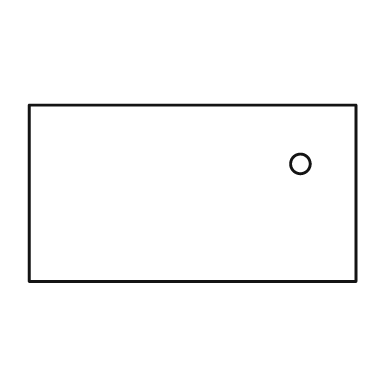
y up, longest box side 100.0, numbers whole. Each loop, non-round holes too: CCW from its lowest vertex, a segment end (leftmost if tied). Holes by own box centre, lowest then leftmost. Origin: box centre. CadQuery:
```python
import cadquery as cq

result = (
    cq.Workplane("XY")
    .moveTo(-50.0, -27.0)
    .lineTo(50.0, -27.0)
    .lineTo(50.0, 27.0)
    .lineTo(-50.0, 27.0)
    .close()
    .moveTo(33.0, 9.0)
    .circle(3.0)
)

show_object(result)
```